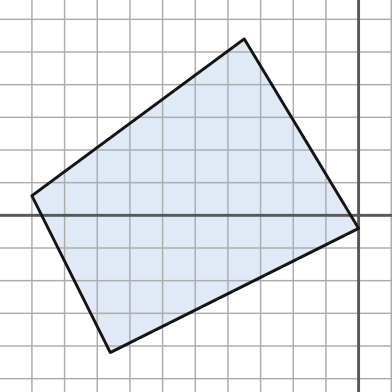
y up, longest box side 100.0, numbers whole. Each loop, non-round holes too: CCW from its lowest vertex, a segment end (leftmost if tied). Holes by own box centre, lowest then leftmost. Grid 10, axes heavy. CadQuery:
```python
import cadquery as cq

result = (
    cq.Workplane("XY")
    .moveTo(-76.0, -42.0)
    .lineTo(0.0, -4.0)
    .lineTo(-35.0, 54.0)
    .lineTo(-100.0, 6.0)
    .close()
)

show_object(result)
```